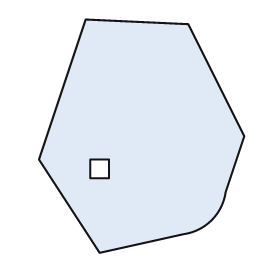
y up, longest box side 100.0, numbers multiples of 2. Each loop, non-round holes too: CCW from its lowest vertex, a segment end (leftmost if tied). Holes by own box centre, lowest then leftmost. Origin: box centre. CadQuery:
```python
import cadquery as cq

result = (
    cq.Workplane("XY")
    .moveTo(-18.0, -50.0)
    .lineTo(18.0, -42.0)
    .threePointArc((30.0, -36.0), (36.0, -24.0))
    .lineTo(44.0, 0.0)
    .lineTo(20.0, 48.0)
    .lineTo(-24.0, 50.0)
    .lineTo(-44.0, -10.0)
    .close()
    .moveTo(-22.0, -18.0)
    .lineTo(-14.0, -18.0)
    .lineTo(-14.0, -10.0)
    .lineTo(-22.0, -10.0)
    .close()
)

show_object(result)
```